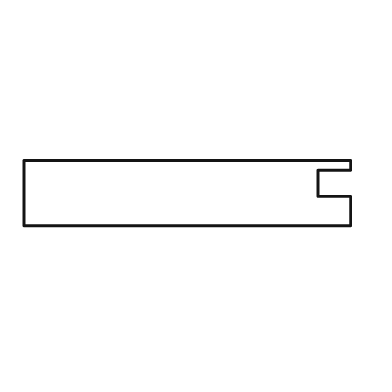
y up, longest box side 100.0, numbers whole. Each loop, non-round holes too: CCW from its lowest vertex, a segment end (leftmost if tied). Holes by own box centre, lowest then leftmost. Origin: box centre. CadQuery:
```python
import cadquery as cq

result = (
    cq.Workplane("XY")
    .moveTo(-50.0, -10.0)
    .lineTo(50.0, -10.0)
    .lineTo(50.0, -1.0)
    .lineTo(40.0, -1.0)
    .lineTo(40.0, 7.0)
    .lineTo(50.0, 7.0)
    .lineTo(50.0, 10.0)
    .lineTo(-50.0, 10.0)
    .close()
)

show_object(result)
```